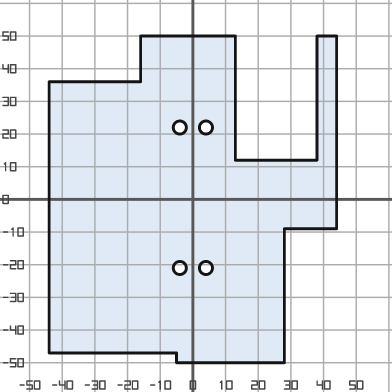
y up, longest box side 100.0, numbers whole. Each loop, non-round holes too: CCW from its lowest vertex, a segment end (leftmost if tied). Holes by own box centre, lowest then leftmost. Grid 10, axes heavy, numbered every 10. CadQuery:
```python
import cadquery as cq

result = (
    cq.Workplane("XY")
    .moveTo(-5.0, -50.0)
    .lineTo(28.0, -50.0)
    .lineTo(28.0, -9.0)
    .lineTo(44.0, -9.0)
    .lineTo(44.0, 50.0)
    .lineTo(38.0, 50.0)
    .lineTo(38.0, 12.0)
    .lineTo(13.0, 12.0)
    .lineTo(13.0, 50.0)
    .lineTo(-16.0, 50.0)
    .lineTo(-16.0, 36.0)
    .lineTo(-44.0, 36.0)
    .lineTo(-44.0, -47.0)
    .lineTo(-5.0, -47.0)
    .close()
    .moveTo(-4.0, -21.0)
    .circle(2.0)
    .moveTo(4.0, -21.0)
    .circle(2.0)
    .moveTo(-4.0, 22.0)
    .circle(2.0)
    .moveTo(4.0, 22.0)
    .circle(2.0)
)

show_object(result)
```